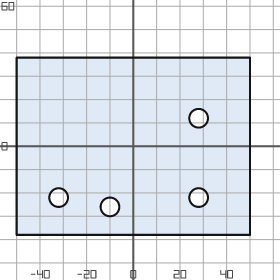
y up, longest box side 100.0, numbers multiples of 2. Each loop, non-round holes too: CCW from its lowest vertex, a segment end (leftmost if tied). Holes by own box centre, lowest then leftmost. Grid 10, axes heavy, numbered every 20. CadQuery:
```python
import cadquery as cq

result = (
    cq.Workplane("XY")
    .moveTo(-50.0, -38.0)
    .lineTo(50.0, -38.0)
    .lineTo(50.0, 38.0)
    .lineTo(-50.0, 38.0)
    .close()
    .moveTo(-10.0, -26.0)
    .circle(4.0)
    .moveTo(-32.0, -22.0)
    .circle(4.0)
    .moveTo(28.0, -22.0)
    .circle(4.0)
    .moveTo(28.0, 12.0)
    .circle(4.0)
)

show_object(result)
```